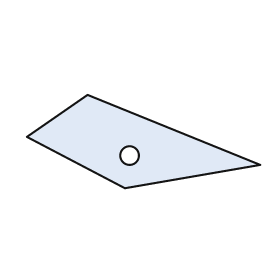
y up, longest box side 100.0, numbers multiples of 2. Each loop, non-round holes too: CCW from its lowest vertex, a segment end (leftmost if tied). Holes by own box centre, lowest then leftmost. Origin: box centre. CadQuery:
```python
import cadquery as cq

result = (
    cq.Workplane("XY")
    .moveTo(-8.0, -20.0)
    .lineTo(50.0, -10.0)
    .lineTo(-24.0, 20.0)
    .lineTo(-50.0, 2.0)
    .close()
    .moveTo(-6.0, -6.0)
    .circle(4.0)
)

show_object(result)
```